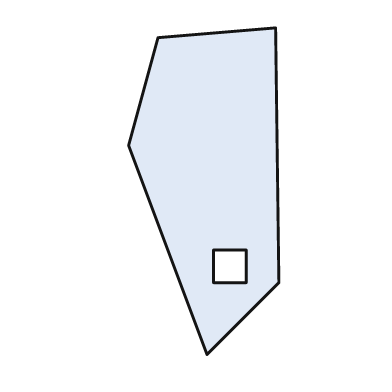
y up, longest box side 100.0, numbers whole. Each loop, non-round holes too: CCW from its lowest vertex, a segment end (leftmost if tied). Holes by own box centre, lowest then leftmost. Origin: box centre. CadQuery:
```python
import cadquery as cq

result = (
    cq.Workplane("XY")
    .moveTo(1.0, -50.0)
    .lineTo(23.0, -28.0)
    .lineTo(22.0, 50.0)
    .lineTo(-14.0, 47.0)
    .lineTo(-23.0, 14.0)
    .close()
    .moveTo(3.0, -28.0)
    .lineTo(13.0, -28.0)
    .lineTo(13.0, -18.0)
    .lineTo(3.0, -18.0)
    .close()
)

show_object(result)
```